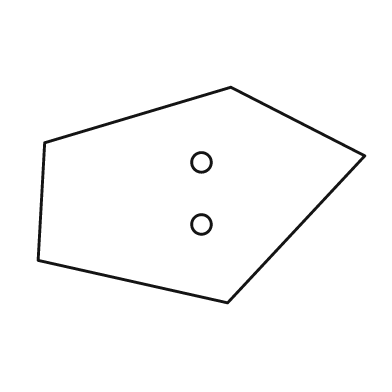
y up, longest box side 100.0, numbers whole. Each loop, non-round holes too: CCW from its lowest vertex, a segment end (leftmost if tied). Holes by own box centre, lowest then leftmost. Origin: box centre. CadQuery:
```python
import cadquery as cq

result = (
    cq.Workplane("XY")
    .moveTo(8.0, -33.0)
    .lineTo(50.0, 12.0)
    .lineTo(9.0, 33.0)
    .lineTo(-48.0, 16.0)
    .lineTo(-50.0, -20.0)
    .close()
    .moveTo(0.0, -9.0)
    .circle(3.0)
    .moveTo(0.0, 10.0)
    .circle(3.0)
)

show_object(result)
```